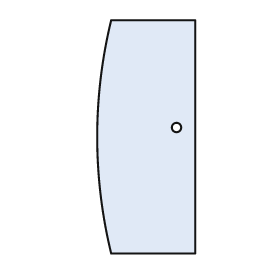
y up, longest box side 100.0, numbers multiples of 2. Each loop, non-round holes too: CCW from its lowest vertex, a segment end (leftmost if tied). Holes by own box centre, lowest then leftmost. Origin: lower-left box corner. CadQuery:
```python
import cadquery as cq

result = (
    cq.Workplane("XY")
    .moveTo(6.0, 0.0)
    .lineTo(42.0, 0.0)
    .lineTo(42.0, 100.0)
    .lineTo(6.0, 100.0)
    .threePointArc((0.0, 50.0), (6.0, 0.0))
    .close()
    .moveTo(34.0, 54.0)
    .circle(2.0)
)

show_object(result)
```